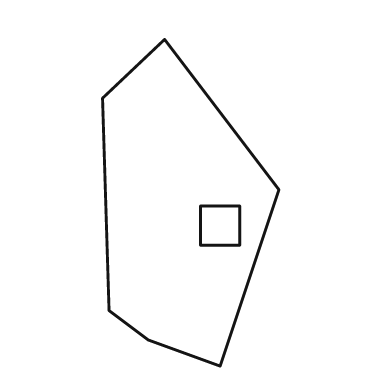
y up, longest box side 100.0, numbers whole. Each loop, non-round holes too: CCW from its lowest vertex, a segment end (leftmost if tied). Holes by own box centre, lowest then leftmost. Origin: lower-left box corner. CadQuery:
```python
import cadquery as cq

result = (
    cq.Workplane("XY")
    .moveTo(36.0, 0.0)
    .lineTo(54.0, 54.0)
    .lineTo(19.0, 100.0)
    .lineTo(0.0, 82.0)
    .lineTo(2.0, 17.0)
    .lineTo(14.0, 8.0)
    .close()
    .moveTo(30.0, 37.0)
    .lineTo(42.0, 37.0)
    .lineTo(42.0, 49.0)
    .lineTo(30.0, 49.0)
    .close()
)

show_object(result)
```